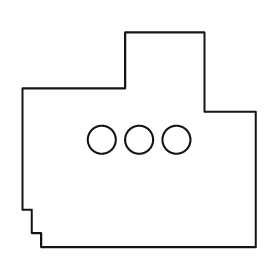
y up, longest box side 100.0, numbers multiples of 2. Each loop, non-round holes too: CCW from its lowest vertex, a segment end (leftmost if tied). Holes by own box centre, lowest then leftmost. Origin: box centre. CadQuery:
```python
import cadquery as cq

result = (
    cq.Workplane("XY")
    .moveTo(-42.0, -46.0)
    .lineTo(50.0, -46.0)
    .lineTo(50.0, 12.0)
    .lineTo(28.0, 12.0)
    .lineTo(28.0, 46.0)
    .lineTo(-6.0, 46.0)
    .lineTo(-6.0, 22.0)
    .lineTo(-50.0, 22.0)
    .lineTo(-50.0, -30.0)
    .lineTo(-46.0, -30.0)
    .lineTo(-46.0, -40.0)
    .lineTo(-42.0, -40.0)
    .close()
    .moveTo(-16.0, 0.0)
    .circle(6.0)
    .moveTo(0.0, 0.0)
    .circle(6.0)
    .moveTo(16.0, 0.0)
    .circle(6.0)
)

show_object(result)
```